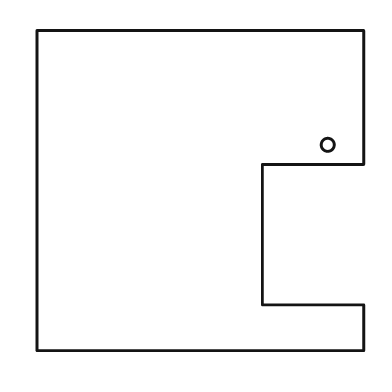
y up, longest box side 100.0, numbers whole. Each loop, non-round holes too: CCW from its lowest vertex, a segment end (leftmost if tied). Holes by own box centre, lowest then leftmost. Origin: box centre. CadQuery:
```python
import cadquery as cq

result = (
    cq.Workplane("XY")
    .moveTo(-50.0, -49.0)
    .lineTo(50.0, -49.0)
    .lineTo(50.0, -35.0)
    .lineTo(19.0, -35.0)
    .lineTo(19.0, 8.0)
    .lineTo(50.0, 8.0)
    .lineTo(50.0, 49.0)
    .lineTo(-50.0, 49.0)
    .close()
    .moveTo(39.0, 14.0)
    .circle(2.0)
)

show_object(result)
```